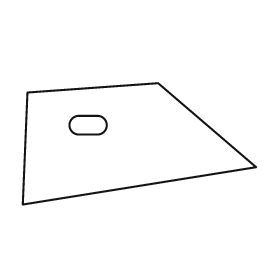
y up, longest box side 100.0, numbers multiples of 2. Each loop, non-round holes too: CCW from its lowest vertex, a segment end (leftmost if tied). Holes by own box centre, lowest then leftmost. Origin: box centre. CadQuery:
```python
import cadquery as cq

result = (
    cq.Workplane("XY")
    .moveTo(-50.0, -26.0)
    .lineTo(50.0, -10.0)
    .lineTo(8.0, 26.0)
    .lineTo(-48.0, 22.0)
    .close()
    .moveTo(-26.0, 4.0)
    .lineTo(-18.0, 4.0)
    .threePointArc((-14.0, 8.0), (-18.0, 12.0))
    .lineTo(-26.0, 12.0)
    .threePointArc((-30.0, 8.0), (-26.0, 4.0))
    .close()
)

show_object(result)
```